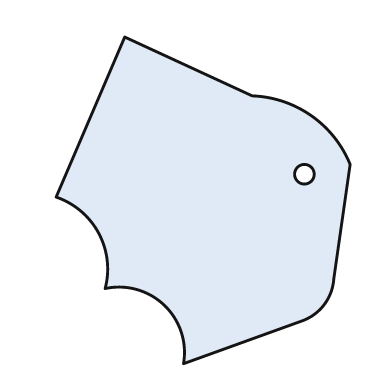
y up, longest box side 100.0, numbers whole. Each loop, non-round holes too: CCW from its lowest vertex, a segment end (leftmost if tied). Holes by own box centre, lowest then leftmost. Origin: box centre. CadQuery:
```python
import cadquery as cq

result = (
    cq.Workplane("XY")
    .moveTo(-6.0, -50.0)
    .lineTo(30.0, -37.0)
    .threePointArc((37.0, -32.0), (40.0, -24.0))
    .lineTo(45.0, 11.0)
    .threePointArc((33.0, 26.0), (15.0, 32.0))
    .lineTo(-24.0, 50.0)
    .lineTo(-45.0, 1.0)
    .threePointArc((-32.0, -10.0), (-30.0, -27.0))
    .threePointArc((-12.0, -32.0), (-6.0, -50.0))
    .close()
    .moveTo(31.0, 8.0)
    .circle(3.0)
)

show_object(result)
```